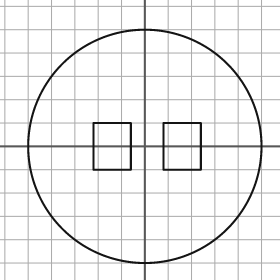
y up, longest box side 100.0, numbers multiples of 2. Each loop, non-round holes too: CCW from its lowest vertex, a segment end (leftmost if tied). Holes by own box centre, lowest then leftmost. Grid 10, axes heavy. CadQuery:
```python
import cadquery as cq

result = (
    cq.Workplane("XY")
    .moveTo(0.0, 0.0)
    .circle(50.0)
    .moveTo(-22.0, -10.0)
    .lineTo(-6.0, -10.0)
    .lineTo(-6.0, 10.0)
    .lineTo(-22.0, 10.0)
    .close()
    .moveTo(8.0, -10.0)
    .lineTo(24.0, -10.0)
    .lineTo(24.0, 10.0)
    .lineTo(8.0, 10.0)
    .close()
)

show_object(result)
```